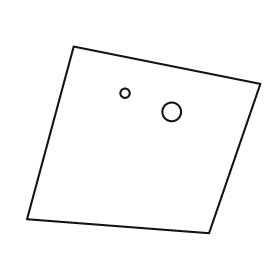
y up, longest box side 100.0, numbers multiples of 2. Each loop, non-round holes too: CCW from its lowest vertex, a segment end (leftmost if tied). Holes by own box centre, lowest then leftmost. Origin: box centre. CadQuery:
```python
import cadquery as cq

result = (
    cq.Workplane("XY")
    .moveTo(28.0, -40.0)
    .lineTo(50.0, 24.0)
    .lineTo(-30.0, 40.0)
    .lineTo(-50.0, -34.0)
    .close()
    .moveTo(12.0, 12.0)
    .circle(4.0)
    .moveTo(-8.0, 20.0)
    .circle(2.0)
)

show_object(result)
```